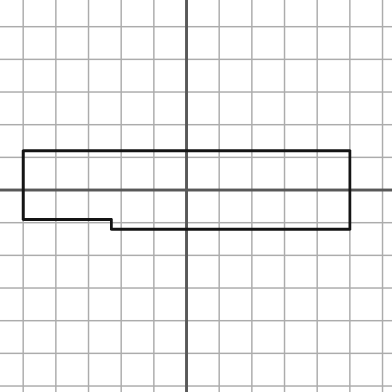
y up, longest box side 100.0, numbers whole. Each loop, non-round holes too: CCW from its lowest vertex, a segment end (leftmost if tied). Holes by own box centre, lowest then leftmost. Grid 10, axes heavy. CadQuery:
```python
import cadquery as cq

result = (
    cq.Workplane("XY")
    .moveTo(-23.0, -12.0)
    .lineTo(50.0, -12.0)
    .lineTo(50.0, 12.0)
    .lineTo(-50.0, 12.0)
    .lineTo(-50.0, -9.0)
    .lineTo(-23.0, -9.0)
    .close()
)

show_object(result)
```